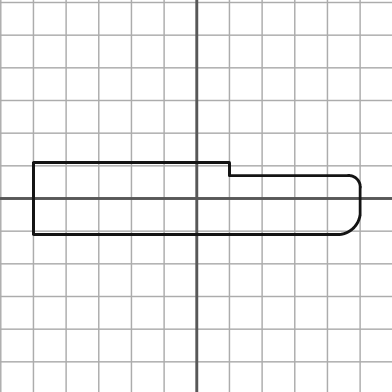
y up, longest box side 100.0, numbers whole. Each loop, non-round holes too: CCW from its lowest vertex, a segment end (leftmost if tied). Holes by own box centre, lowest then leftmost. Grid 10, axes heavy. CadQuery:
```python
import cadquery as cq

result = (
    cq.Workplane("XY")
    .moveTo(-50.0, -11.0)
    .lineTo(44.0, -11.0)
    .threePointArc((48.0, -9.0), (50.0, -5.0))
    .lineTo(50.0, 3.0)
    .threePointArc((49.0, 6.0), (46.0, 7.0))
    .lineTo(10.0, 7.0)
    .lineTo(10.0, 11.0)
    .lineTo(-50.0, 11.0)
    .close()
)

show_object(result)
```